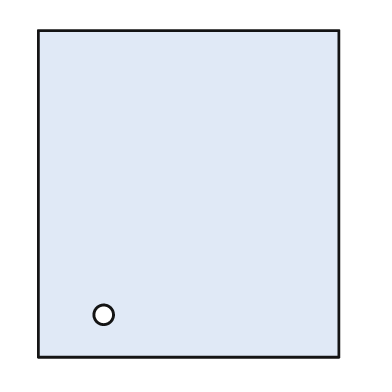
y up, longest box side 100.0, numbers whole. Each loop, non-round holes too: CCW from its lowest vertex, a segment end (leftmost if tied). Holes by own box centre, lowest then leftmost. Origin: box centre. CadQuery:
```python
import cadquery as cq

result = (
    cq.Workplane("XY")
    .moveTo(-46.0, -50.0)
    .lineTo(46.0, -50.0)
    .lineTo(46.0, 50.0)
    .lineTo(-46.0, 50.0)
    .close()
    .moveTo(-26.0, -37.0)
    .circle(3.0)
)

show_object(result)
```